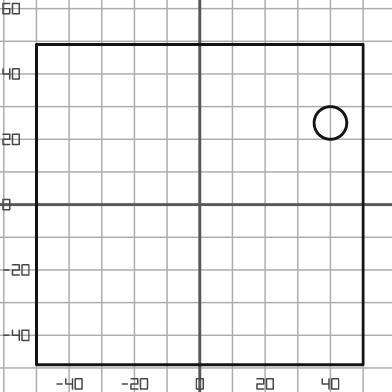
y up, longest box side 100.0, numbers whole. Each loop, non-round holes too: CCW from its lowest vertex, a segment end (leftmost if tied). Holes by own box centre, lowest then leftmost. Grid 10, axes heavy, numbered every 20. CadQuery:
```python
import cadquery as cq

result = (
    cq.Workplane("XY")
    .moveTo(-50.0, -49.0)
    .lineTo(50.0, -49.0)
    .lineTo(50.0, 49.0)
    .lineTo(-50.0, 49.0)
    .close()
    .moveTo(40.0, 25.0)
    .circle(5.0)
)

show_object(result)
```